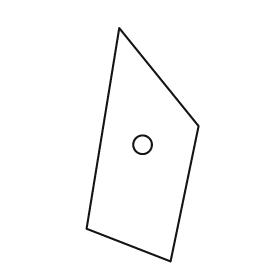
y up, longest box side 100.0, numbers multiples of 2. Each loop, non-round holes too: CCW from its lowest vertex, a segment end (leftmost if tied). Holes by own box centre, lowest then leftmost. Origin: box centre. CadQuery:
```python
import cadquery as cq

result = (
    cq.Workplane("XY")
    .moveTo(12.0, -50.0)
    .lineTo(24.0, 8.0)
    .lineTo(-10.0, 50.0)
    .lineTo(-24.0, -36.0)
    .close()
    .moveTo(0.0, 0.0)
    .circle(4.0)
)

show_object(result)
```